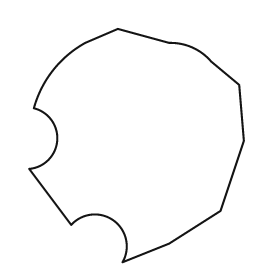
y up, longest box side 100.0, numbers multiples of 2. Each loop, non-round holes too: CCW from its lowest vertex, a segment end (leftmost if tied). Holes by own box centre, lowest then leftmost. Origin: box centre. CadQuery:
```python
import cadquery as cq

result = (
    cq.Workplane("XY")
    .moveTo(-6.0, -50.0)
    .lineTo(14.0, -42.0)
    .lineTo(36.0, -28.0)
    .lineTo(46.0, 2.0)
    .lineTo(44.0, 26.0)
    .lineTo(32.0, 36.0)
    .threePointArc((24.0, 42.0), (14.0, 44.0))
    .lineTo(-8.0, 50.0)
    .lineTo(-22.0, 44.0)
    .threePointArc((-36.0, 32.0), (-44.0, 16.0))
    .threePointArc((-34.0, 2.0), (-46.0, -10.0))
    .lineTo(-28.0, -34.0)
    .threePointArc((-10.0, -32.0), (-6.0, -50.0))
    .close()
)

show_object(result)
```